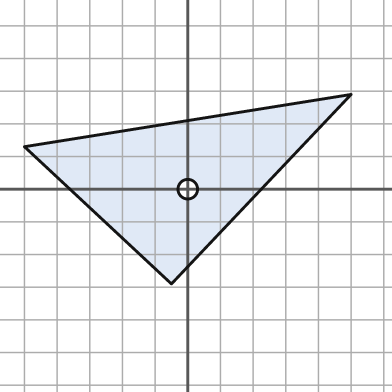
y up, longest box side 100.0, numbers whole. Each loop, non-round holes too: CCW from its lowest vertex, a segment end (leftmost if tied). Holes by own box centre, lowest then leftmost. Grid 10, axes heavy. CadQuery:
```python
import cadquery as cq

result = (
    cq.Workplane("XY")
    .moveTo(-5.0, -29.0)
    .lineTo(50.0, 29.0)
    .lineTo(-50.0, 13.0)
    .close()
    .moveTo(0.0, 0.0)
    .circle(3.0)
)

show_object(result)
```